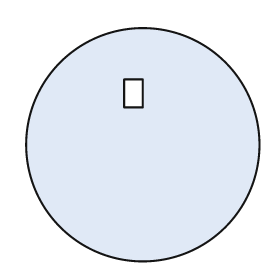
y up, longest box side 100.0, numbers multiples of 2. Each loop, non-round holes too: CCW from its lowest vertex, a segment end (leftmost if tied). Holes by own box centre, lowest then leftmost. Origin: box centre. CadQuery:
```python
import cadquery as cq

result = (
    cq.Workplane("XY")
    .moveTo(0.0, 0.0)
    .circle(50.0)
    .moveTo(-8.0, 16.0)
    .lineTo(0.0, 16.0)
    .lineTo(0.0, 28.0)
    .lineTo(-8.0, 28.0)
    .close()
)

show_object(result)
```